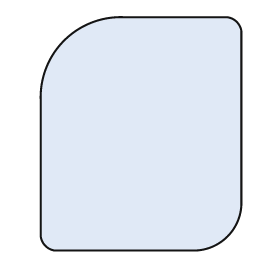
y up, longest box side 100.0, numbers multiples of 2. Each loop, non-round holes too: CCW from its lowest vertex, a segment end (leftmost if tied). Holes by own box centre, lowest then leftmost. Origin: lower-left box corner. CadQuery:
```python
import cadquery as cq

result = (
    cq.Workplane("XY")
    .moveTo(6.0, 0.0)
    .lineTo(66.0, 0.0)
    .threePointArc((80.0, 6.0), (86.0, 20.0))
    .lineTo(86.0, 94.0)
    .threePointArc((84.0, 98.0), (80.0, 100.0))
    .lineTo(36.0, 100.0)
    .threePointArc((10.0, 90.0), (0.0, 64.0))
    .lineTo(0.0, 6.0)
    .threePointArc((2.0, 2.0), (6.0, 0.0))
    .close()
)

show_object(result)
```